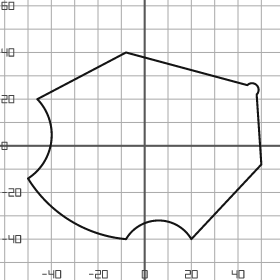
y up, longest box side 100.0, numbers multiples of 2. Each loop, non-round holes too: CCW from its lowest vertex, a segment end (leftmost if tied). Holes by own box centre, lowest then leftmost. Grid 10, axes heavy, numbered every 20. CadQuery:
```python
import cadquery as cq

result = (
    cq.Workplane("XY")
    .moveTo(-8.0, -40.0)
    .threePointArc((6.0, -32.0), (20.0, -40.0))
    .lineTo(50.0, -8.0)
    .lineTo(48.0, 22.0)
    .threePointArc((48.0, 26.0), (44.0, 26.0))
    .lineTo(-8.0, 40.0)
    .lineTo(-46.0, 20.0)
    .threePointArc((-40.0, 2.0), (-50.0, -14.0))
    .threePointArc((-32.0, -32.0), (-8.0, -40.0))
    .close()
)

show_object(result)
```